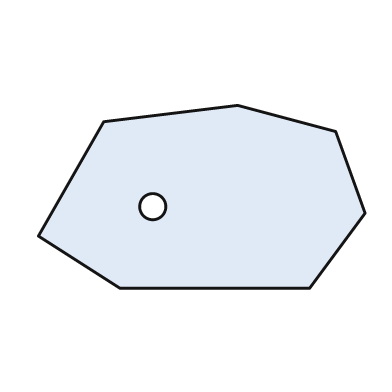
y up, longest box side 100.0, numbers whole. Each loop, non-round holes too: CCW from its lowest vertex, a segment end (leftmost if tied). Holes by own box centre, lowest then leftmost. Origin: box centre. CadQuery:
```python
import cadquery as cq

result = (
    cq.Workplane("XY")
    .moveTo(-25.0, -28.0)
    .lineTo(33.0, -28.0)
    .lineTo(50.0, -5.0)
    .lineTo(41.0, 20.0)
    .lineTo(11.0, 28.0)
    .lineTo(-30.0, 23.0)
    .lineTo(-50.0, -12.0)
    .close()
    .moveTo(-15.0, -3.0)
    .circle(4.0)
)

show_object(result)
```